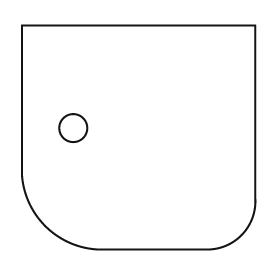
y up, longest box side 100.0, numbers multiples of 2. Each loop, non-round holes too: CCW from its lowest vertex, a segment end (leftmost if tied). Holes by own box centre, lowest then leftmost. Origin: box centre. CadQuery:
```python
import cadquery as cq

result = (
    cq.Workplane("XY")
    .moveTo(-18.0, -48.0)
    .lineTo(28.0, -48.0)
    .threePointArc((44.0, -42.0), (50.0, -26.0))
    .lineTo(50.0, 48.0)
    .lineTo(-50.0, 48.0)
    .lineTo(-50.0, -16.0)
    .threePointArc((-40.0, -38.0), (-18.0, -48.0))
    .close()
    .moveTo(-28.0, 4.0)
    .circle(6.0)
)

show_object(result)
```